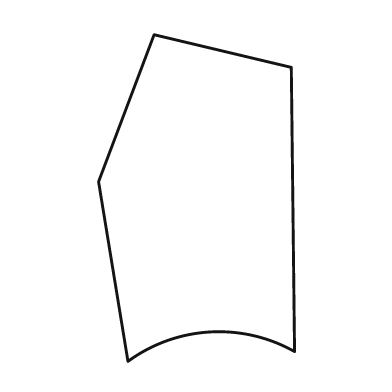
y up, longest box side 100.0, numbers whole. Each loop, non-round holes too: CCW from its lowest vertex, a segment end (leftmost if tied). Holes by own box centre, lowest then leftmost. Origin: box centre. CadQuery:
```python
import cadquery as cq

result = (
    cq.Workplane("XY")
    .moveTo(-21.0, -50.0)
    .threePointArc((4.0, -41.0), (30.0, -47.0))
    .lineTo(29.0, 40.0)
    .lineTo(-13.0, 50.0)
    .lineTo(-30.0, 5.0)
    .close()
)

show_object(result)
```